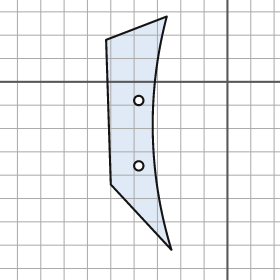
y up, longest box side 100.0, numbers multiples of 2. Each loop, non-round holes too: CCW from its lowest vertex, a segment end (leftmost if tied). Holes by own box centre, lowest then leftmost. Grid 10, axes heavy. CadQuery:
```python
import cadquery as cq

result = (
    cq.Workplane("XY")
    .moveTo(-24.0, -72.0)
    .threePointArc((-32.0, -22.0), (-26.0, 28.0))
    .lineTo(-52.0, 18.0)
    .lineTo(-50.0, -44.0)
    .close()
    .moveTo(-38.0, -36.0)
    .circle(2.0)
    .moveTo(-38.0, -8.0)
    .circle(2.0)
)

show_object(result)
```